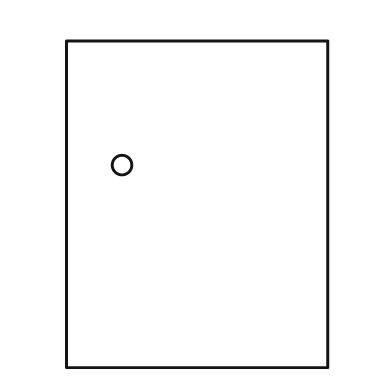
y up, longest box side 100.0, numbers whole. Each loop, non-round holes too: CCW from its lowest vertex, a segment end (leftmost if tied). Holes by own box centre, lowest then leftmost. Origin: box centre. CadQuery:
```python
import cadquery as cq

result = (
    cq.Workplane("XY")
    .moveTo(-40.0, -50.0)
    .lineTo(40.0, -50.0)
    .lineTo(40.0, 50.0)
    .lineTo(-40.0, 50.0)
    .close()
    .moveTo(-23.0, 12.0)
    .circle(3.0)
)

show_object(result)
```